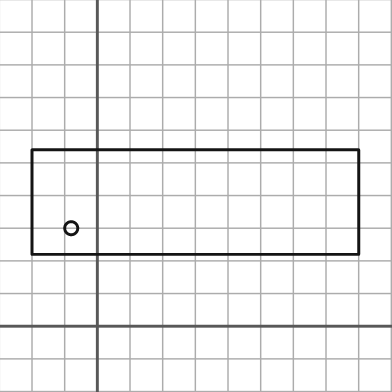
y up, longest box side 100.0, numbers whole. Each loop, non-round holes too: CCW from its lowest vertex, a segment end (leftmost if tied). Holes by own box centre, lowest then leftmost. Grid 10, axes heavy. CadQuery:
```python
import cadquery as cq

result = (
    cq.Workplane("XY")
    .moveTo(-20.0, 22.0)
    .lineTo(80.0, 22.0)
    .lineTo(80.0, 54.0)
    .lineTo(-20.0, 54.0)
    .close()
    .moveTo(-8.0, 30.0)
    .circle(2.0)
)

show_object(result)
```